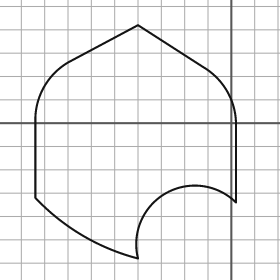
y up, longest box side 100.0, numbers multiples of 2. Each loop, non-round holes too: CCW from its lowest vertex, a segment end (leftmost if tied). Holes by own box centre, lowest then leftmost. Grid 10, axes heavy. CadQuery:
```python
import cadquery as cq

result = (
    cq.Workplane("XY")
    .moveTo(-40.0, -58.0)
    .threePointArc((-28.0, -30.0), (2.0, -34.0))
    .lineTo(2.0, 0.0)
    .threePointArc((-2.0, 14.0), (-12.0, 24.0))
    .lineTo(-40.0, 42.0)
    .lineTo(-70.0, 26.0)
    .threePointArc((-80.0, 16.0), (-84.0, 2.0))
    .lineTo(-84.0, -32.0)
    .threePointArc((-64.0, -48.0), (-40.0, -58.0))
    .close()
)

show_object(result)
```